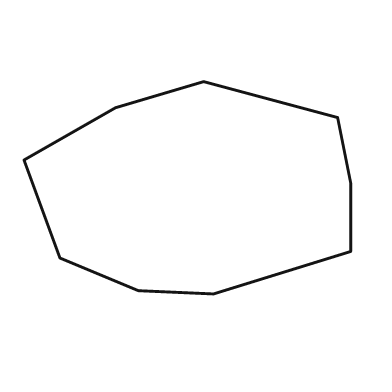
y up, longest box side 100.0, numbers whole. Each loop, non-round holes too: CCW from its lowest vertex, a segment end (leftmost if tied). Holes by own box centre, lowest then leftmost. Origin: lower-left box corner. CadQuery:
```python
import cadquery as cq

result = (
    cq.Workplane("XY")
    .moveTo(58.0, 0.0)
    .lineTo(100.0, 13.0)
    .lineTo(100.0, 34.0)
    .lineTo(96.0, 54.0)
    .lineTo(55.0, 65.0)
    .lineTo(28.0, 57.0)
    .lineTo(0.0, 41.0)
    .lineTo(11.0, 11.0)
    .lineTo(35.0, 1.0)
    .close()
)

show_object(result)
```